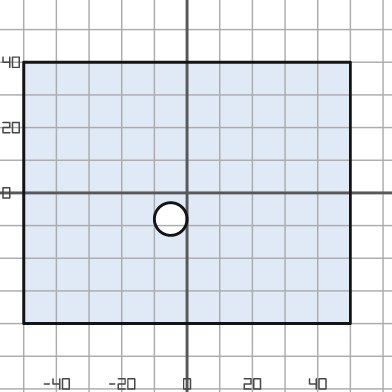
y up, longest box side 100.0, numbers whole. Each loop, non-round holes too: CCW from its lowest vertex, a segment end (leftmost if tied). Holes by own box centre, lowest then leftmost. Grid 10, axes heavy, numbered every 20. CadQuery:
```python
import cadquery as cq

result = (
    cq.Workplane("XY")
    .moveTo(-50.0, -40.0)
    .lineTo(50.0, -40.0)
    .lineTo(50.0, 40.0)
    .lineTo(-50.0, 40.0)
    .close()
    .moveTo(-5.0, -8.0)
    .circle(5.0)
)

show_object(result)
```